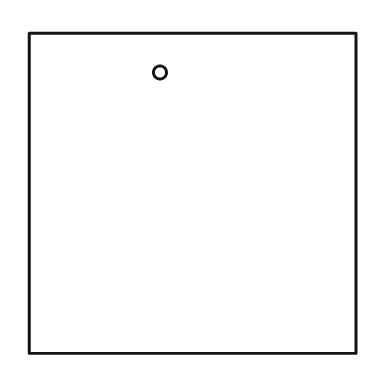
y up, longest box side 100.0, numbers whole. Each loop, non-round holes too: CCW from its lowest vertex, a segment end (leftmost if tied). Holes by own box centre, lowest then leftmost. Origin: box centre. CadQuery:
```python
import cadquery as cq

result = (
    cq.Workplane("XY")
    .moveTo(-50.0, -49.0)
    .lineTo(50.0, -49.0)
    .lineTo(50.0, 49.0)
    .lineTo(-50.0, 49.0)
    .close()
    .moveTo(-10.0, 37.0)
    .circle(2.0)
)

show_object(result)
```